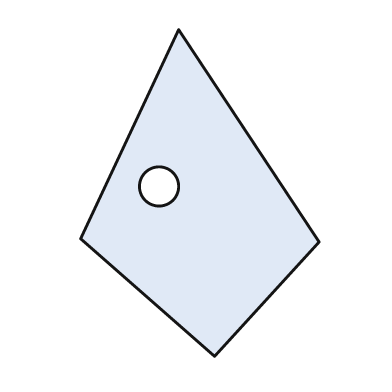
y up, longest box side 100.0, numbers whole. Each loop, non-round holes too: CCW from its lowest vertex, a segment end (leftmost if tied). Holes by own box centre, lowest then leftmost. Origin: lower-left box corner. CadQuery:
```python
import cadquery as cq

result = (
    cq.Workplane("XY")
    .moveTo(41.0, 0.0)
    .lineTo(73.0, 35.0)
    .lineTo(30.0, 100.0)
    .lineTo(0.0, 36.0)
    .close()
    .moveTo(24.0, 52.0)
    .circle(6.0)
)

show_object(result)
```